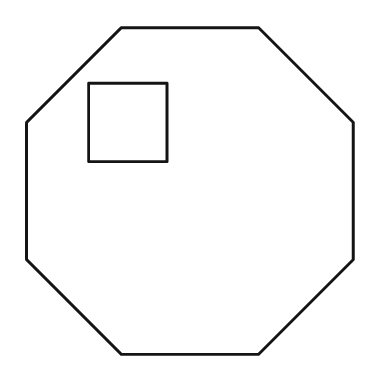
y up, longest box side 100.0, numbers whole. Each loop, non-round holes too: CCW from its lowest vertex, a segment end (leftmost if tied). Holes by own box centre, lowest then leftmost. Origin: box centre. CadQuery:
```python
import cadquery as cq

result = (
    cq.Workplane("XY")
    .moveTo(-21.0, -50.0)
    .lineTo(21.0, -50.0)
    .lineTo(50.0, -21.0)
    .lineTo(50.0, 21.0)
    .lineTo(21.0, 50.0)
    .lineTo(-21.0, 50.0)
    .lineTo(-50.0, 21.0)
    .lineTo(-50.0, -21.0)
    .close()
    .moveTo(-31.0, 9.0)
    .lineTo(-7.0, 9.0)
    .lineTo(-7.0, 33.0)
    .lineTo(-31.0, 33.0)
    .close()
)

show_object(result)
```